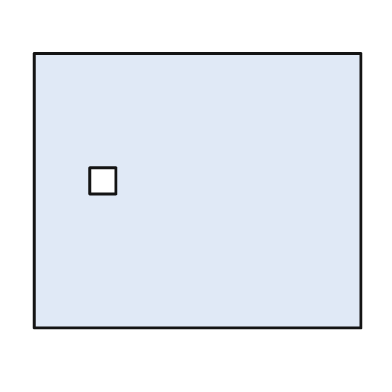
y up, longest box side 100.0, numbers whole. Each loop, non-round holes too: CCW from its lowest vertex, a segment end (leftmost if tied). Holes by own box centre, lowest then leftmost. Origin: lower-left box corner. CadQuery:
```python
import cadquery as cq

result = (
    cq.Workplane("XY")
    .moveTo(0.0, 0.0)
    .lineTo(100.0, 0.0)
    .lineTo(100.0, 84.0)
    .lineTo(0.0, 84.0)
    .close()
    .moveTo(17.0, 41.0)
    .lineTo(25.0, 41.0)
    .lineTo(25.0, 49.0)
    .lineTo(17.0, 49.0)
    .close()
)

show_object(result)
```